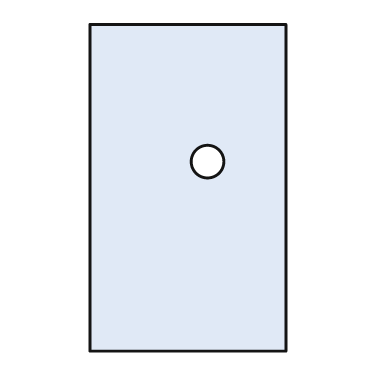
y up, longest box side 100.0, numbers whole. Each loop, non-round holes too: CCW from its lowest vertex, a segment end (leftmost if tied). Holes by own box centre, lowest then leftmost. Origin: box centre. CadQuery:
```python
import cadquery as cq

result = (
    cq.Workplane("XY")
    .moveTo(-30.0, -50.0)
    .lineTo(30.0, -50.0)
    .lineTo(30.0, 50.0)
    .lineTo(-30.0, 50.0)
    .close()
    .moveTo(6.0, 8.0)
    .circle(5.0)
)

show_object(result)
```